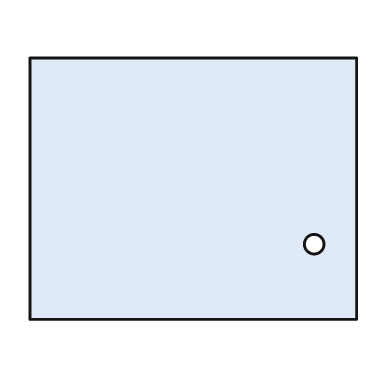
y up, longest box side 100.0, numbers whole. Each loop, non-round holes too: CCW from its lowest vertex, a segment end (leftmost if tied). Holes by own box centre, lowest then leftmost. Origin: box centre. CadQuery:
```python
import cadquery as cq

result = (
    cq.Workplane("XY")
    .moveTo(-50.0, -40.0)
    .lineTo(50.0, -40.0)
    .lineTo(50.0, 40.0)
    .lineTo(-50.0, 40.0)
    .close()
    .moveTo(37.0, -17.0)
    .circle(3.0)
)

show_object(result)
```